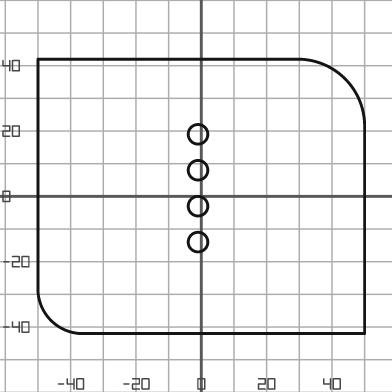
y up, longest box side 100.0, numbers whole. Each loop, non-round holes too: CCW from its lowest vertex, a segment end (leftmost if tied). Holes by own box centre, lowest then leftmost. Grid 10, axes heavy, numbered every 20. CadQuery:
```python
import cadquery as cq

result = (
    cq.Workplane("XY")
    .moveTo(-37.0, -42.0)
    .lineTo(50.0, -42.0)
    .lineTo(50.0, 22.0)
    .threePointArc((44.0, 36.0), (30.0, 42.0))
    .lineTo(-50.0, 42.0)
    .lineTo(-50.0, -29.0)
    .threePointArc((-46.0, -38.0), (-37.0, -42.0))
    .close()
    .moveTo(-1.0, -14.0)
    .circle(3.0)
    .moveTo(-1.0, -3.0)
    .circle(3.0)
    .moveTo(-1.0, 8.0)
    .circle(3.0)
    .moveTo(-1.0, 19.0)
    .circle(3.0)
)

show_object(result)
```